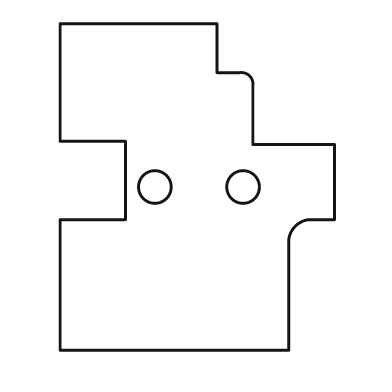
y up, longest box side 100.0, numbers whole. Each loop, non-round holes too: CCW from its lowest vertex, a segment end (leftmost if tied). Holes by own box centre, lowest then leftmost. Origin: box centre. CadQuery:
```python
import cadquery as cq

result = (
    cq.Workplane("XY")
    .moveTo(-42.0, -50.0)
    .lineTo(28.0, -50.0)
    .lineTo(28.0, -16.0)
    .threePointArc((30.0, -12.0), (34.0, -10.0))
    .lineTo(42.0, -10.0)
    .lineTo(42.0, 13.0)
    .lineTo(17.0, 13.0)
    .lineTo(17.0, 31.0)
    .threePointArc((16.0, 34.0), (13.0, 35.0))
    .lineTo(6.0, 35.0)
    .lineTo(6.0, 50.0)
    .lineTo(-42.0, 50.0)
    .lineTo(-42.0, 14.0)
    .lineTo(-22.0, 14.0)
    .lineTo(-22.0, -10.0)
    .lineTo(-42.0, -10.0)
    .close()
    .moveTo(-13.0, 0.0)
    .circle(5.0)
    .moveTo(14.0, 0.0)
    .circle(5.0)
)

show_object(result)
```